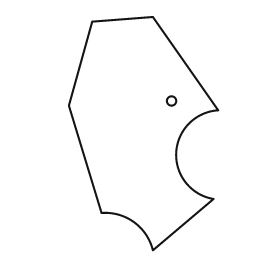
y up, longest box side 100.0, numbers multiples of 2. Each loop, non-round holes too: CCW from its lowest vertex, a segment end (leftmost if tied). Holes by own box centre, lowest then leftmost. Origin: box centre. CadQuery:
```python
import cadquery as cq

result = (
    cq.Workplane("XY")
    .moveTo(4.0, -50.0)
    .lineTo(30.0, -28.0)
    .threePointArc((14.0, -8.0), (32.0, 10.0))
    .lineTo(4.0, 50.0)
    .lineTo(-22.0, 48.0)
    .lineTo(-32.0, 12.0)
    .lineTo(-18.0, -34.0)
    .threePointArc((-4.0, -38.0), (4.0, -50.0))
    .close()
    .moveTo(12.0, 14.0)
    .circle(2.0)
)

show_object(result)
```